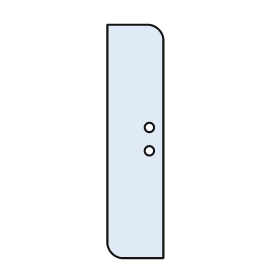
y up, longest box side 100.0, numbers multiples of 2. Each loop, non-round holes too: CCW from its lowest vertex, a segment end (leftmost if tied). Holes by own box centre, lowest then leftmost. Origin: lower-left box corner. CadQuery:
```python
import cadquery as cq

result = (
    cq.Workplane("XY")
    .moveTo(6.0, 0.0)
    .lineTo(24.0, 0.0)
    .lineTo(24.0, 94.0)
    .threePointArc((22.0, 98.0), (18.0, 100.0))
    .lineTo(0.0, 100.0)
    .lineTo(0.0, 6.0)
    .threePointArc((2.0, 2.0), (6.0, 0.0))
    .close()
    .moveTo(18.0, 46.0)
    .circle(2.0)
    .moveTo(18.0, 56.0)
    .circle(2.0)
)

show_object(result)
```